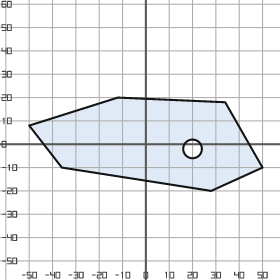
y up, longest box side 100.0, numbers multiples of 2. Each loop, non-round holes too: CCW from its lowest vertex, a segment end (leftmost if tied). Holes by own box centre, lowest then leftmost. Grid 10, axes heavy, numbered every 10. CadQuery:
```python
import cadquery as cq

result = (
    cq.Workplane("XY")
    .moveTo(28.0, -20.0)
    .lineTo(50.0, -10.0)
    .lineTo(34.0, 18.0)
    .lineTo(-12.0, 20.0)
    .lineTo(-50.0, 8.0)
    .lineTo(-36.0, -10.0)
    .close()
    .moveTo(20.0, -2.0)
    .circle(4.0)
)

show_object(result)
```